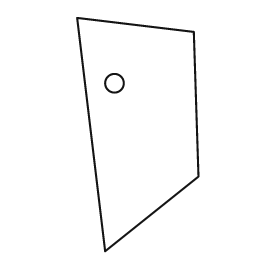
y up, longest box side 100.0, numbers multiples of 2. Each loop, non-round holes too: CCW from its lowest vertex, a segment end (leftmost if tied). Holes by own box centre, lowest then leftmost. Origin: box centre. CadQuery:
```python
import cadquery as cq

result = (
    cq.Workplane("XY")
    .moveTo(-14.0, -50.0)
    .lineTo(26.0, -18.0)
    .lineTo(24.0, 44.0)
    .lineTo(-26.0, 50.0)
    .close()
    .moveTo(-10.0, 22.0)
    .circle(4.0)
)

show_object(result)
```